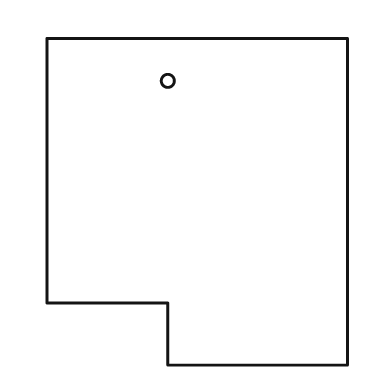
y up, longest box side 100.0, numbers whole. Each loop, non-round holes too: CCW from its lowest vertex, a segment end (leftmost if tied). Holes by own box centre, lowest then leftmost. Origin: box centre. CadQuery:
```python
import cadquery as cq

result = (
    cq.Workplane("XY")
    .moveTo(-9.0, -50.0)
    .lineTo(46.0, -50.0)
    .lineTo(46.0, 50.0)
    .lineTo(-46.0, 50.0)
    .lineTo(-46.0, -31.0)
    .lineTo(-9.0, -31.0)
    .close()
    .moveTo(-9.0, 37.0)
    .circle(2.0)
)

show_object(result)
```